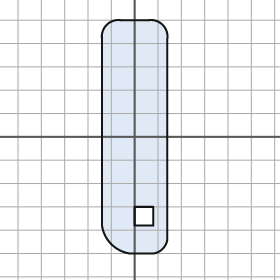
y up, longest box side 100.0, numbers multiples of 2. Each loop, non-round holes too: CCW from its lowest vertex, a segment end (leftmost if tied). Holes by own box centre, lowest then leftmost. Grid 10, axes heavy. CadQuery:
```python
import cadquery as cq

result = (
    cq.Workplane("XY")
    .moveTo(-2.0, -50.0)
    .lineTo(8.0, -50.0)
    .threePointArc((12.0, -48.0), (14.0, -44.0))
    .lineTo(14.0, 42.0)
    .threePointArc((12.0, 48.0), (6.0, 50.0))
    .lineTo(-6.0, 50.0)
    .threePointArc((-12.0, 48.0), (-14.0, 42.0))
    .lineTo(-14.0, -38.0)
    .threePointArc((-10.0, -46.0), (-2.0, -50.0))
    .close()
    .moveTo(0.0, -38.0)
    .lineTo(8.0, -38.0)
    .lineTo(8.0, -30.0)
    .lineTo(0.0, -30.0)
    .close()
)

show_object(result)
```